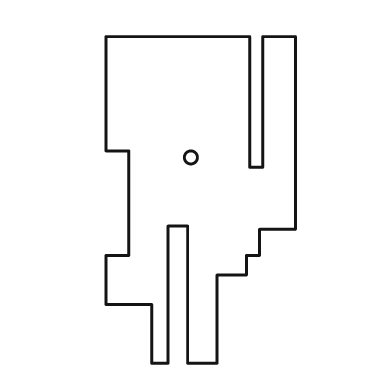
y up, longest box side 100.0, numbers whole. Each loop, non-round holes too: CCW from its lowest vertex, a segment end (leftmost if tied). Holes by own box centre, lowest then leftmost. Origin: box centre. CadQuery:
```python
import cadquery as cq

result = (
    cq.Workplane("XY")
    .moveTo(-15.0, -50.0)
    .lineTo(-10.0, -50.0)
    .lineTo(-10.0, -8.0)
    .lineTo(-4.0, -8.0)
    .lineTo(-4.0, -50.0)
    .lineTo(5.0, -50.0)
    .lineTo(5.0, -23.0)
    .lineTo(14.0, -23.0)
    .lineTo(14.0, -17.0)
    .lineTo(18.0, -17.0)
    .lineTo(18.0, -9.0)
    .lineTo(29.0, -9.0)
    .lineTo(29.0, 50.0)
    .lineTo(19.0, 50.0)
    .lineTo(19.0, 10.0)
    .lineTo(15.0, 10.0)
    .lineTo(15.0, 50.0)
    .lineTo(-29.0, 50.0)
    .lineTo(-29.0, 15.0)
    .lineTo(-22.0, 15.0)
    .lineTo(-22.0, -17.0)
    .lineTo(-29.0, -17.0)
    .lineTo(-29.0, -32.0)
    .lineTo(-15.0, -32.0)
    .close()
    .moveTo(-3.0, 13.0)
    .circle(2.0)
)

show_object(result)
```